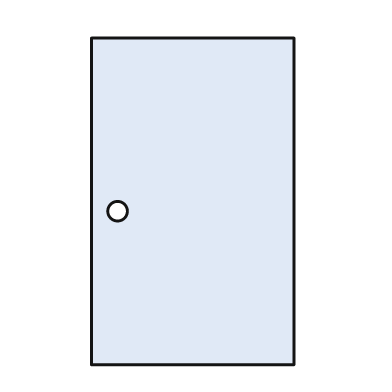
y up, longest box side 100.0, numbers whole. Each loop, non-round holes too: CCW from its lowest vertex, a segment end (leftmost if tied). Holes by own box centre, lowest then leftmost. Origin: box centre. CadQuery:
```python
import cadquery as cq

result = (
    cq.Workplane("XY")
    .moveTo(-31.0, -50.0)
    .lineTo(31.0, -50.0)
    .lineTo(31.0, 50.0)
    .lineTo(-31.0, 50.0)
    .close()
    .moveTo(-23.0, -3.0)
    .circle(3.0)
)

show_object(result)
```